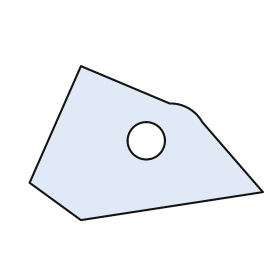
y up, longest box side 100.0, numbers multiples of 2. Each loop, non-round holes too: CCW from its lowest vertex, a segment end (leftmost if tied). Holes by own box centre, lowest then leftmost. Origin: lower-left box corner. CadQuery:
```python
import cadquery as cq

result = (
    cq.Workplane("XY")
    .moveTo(22.0, 0.0)
    .lineTo(100.0, 12.0)
    .lineTo(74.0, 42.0)
    .threePointArc((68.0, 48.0), (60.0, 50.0))
    .lineTo(22.0, 66.0)
    .lineTo(0.0, 16.0)
    .close()
    .moveTo(50.0, 34.0)
    .circle(8.0)
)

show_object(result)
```